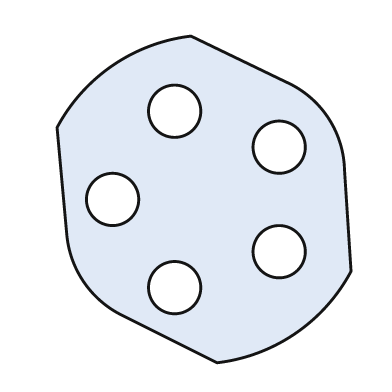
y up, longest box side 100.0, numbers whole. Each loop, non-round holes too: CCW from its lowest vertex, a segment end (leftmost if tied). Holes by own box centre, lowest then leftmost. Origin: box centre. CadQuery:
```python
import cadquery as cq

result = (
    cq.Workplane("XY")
    .moveTo(4.0, -50.0)
    .threePointArc((28.0, -41.0), (45.0, -22.0))
    .lineTo(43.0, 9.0)
    .threePointArc((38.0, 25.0), (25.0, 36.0))
    .lineTo(-4.0, 50.0)
    .threePointArc((-28.0, 41.0), (-45.0, 22.0))
    .lineTo(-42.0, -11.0)
    .threePointArc((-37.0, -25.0), (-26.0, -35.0))
    .close()
    .moveTo(-9.0, -27.0)
    .circle(8.0)
    .moveTo(23.0, -16.0)
    .circle(8.0)
    .moveTo(-28.0, 0.0)
    .circle(8.0)
    .moveTo(23.0, 16.0)
    .circle(8.0)
    .moveTo(-9.0, 27.0)
    .circle(8.0)
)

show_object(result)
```